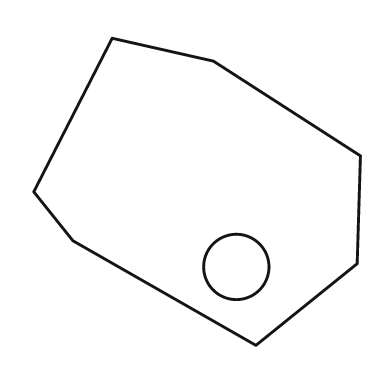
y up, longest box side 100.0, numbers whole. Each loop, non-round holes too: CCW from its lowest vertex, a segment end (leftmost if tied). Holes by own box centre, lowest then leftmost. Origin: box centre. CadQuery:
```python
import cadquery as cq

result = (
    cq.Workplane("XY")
    .moveTo(18.0, -47.0)
    .lineTo(49.0, -22.0)
    .lineTo(50.0, 11.0)
    .lineTo(5.0, 40.0)
    .lineTo(-26.0, 47.0)
    .lineTo(-50.0, 0.0)
    .lineTo(-38.0, -15.0)
    .close()
    .moveTo(12.0, -23.0)
    .circle(10.0)
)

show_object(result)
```